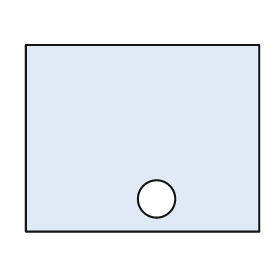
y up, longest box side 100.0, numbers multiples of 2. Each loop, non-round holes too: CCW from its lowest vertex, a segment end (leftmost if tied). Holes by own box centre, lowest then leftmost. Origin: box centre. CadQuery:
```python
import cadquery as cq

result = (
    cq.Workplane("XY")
    .moveTo(-50.0, -40.0)
    .lineTo(50.0, -40.0)
    .lineTo(50.0, 40.0)
    .lineTo(-50.0, 40.0)
    .close()
    .moveTo(6.0, -26.0)
    .circle(8.0)
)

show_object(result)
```